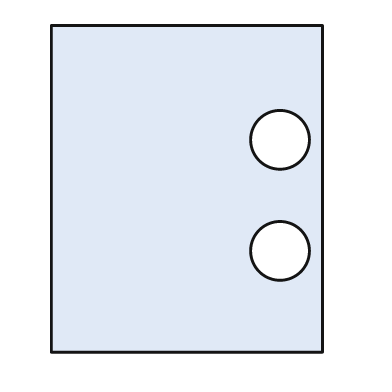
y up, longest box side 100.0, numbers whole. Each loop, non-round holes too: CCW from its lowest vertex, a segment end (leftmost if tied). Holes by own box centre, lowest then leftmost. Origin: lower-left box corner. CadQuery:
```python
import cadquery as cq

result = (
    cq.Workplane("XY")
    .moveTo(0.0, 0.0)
    .lineTo(83.0, 0.0)
    .lineTo(83.0, 100.0)
    .lineTo(0.0, 100.0)
    .close()
    .moveTo(70.0, 31.0)
    .circle(9.0)
    .moveTo(70.0, 65.0)
    .circle(9.0)
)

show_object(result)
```